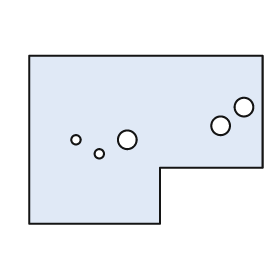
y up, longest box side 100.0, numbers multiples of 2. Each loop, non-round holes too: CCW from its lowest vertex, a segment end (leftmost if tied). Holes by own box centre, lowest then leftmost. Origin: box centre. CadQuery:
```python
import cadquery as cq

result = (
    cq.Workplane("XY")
    .moveTo(-50.0, -36.0)
    .lineTo(6.0, -36.0)
    .lineTo(6.0, -12.0)
    .lineTo(50.0, -12.0)
    .lineTo(50.0, 36.0)
    .lineTo(-50.0, 36.0)
    .close()
    .moveTo(-20.0, -6.0)
    .circle(2.0)
    .moveTo(-30.0, 0.0)
    .circle(2.0)
    .moveTo(-8.0, 0.0)
    .circle(4.0)
    .moveTo(32.0, 6.0)
    .circle(4.0)
    .moveTo(42.0, 14.0)
    .circle(4.0)
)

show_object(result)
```